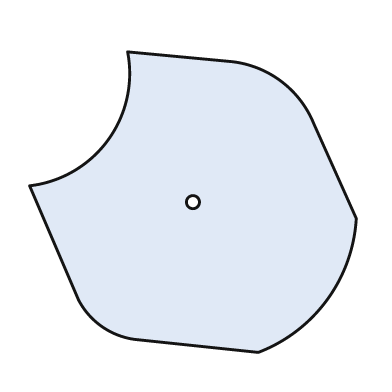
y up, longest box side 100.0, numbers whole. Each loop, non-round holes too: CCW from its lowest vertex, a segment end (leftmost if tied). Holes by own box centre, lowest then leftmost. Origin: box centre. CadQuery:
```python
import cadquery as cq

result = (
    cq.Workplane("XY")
    .moveTo(20.0, -46.0)
    .threePointArc((41.0, -30.0), (50.0, -5.0))
    .lineTo(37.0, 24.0)
    .threePointArc((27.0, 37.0), (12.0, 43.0))
    .lineTo(-20.0, 46.0)
    .threePointArc((-26.0, 19.0), (-50.0, 5.0))
    .lineTo(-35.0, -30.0)
    .threePointArc((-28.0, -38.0), (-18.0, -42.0))
    .close()
    .moveTo(0.0, 0.0)
    .circle(2.0)
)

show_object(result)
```